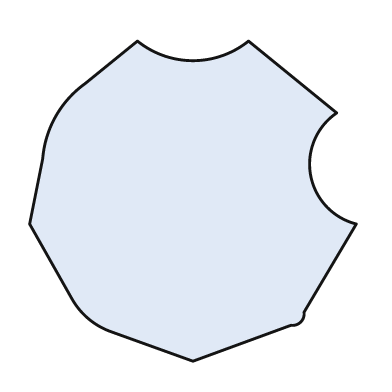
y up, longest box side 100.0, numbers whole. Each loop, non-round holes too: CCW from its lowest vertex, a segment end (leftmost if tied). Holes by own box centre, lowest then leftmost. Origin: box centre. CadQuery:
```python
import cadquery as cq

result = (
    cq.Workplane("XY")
    .moveTo(0.0, -49.0)
    .lineTo(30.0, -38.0)
    .threePointArc((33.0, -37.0), (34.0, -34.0))
    .lineTo(50.0, -7.0)
    .threePointArc((36.0, 8.0), (44.0, 27.0))
    .lineTo(17.0, 49.0)
    .threePointArc((0.0, 43.0), (-17.0, 49.0))
    .lineTo(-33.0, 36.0)
    .threePointArc((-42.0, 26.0), (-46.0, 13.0))
    .lineTo(-50.0, -7.0)
    .lineTo(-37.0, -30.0)
    .threePointArc((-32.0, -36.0), (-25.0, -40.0))
    .close()
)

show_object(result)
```